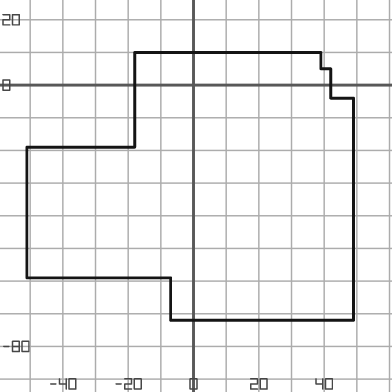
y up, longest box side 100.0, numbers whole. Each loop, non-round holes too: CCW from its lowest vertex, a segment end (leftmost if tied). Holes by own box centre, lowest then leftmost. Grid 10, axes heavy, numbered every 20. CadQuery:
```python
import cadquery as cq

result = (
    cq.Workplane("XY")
    .moveTo(-7.0, -72.0)
    .lineTo(49.0, -72.0)
    .lineTo(49.0, -4.0)
    .lineTo(42.0, -4.0)
    .lineTo(42.0, 5.0)
    .lineTo(39.0, 5.0)
    .lineTo(39.0, 10.0)
    .lineTo(-18.0, 10.0)
    .lineTo(-18.0, -19.0)
    .lineTo(-51.0, -19.0)
    .lineTo(-51.0, -59.0)
    .lineTo(-7.0, -59.0)
    .close()
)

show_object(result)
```